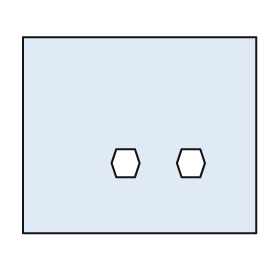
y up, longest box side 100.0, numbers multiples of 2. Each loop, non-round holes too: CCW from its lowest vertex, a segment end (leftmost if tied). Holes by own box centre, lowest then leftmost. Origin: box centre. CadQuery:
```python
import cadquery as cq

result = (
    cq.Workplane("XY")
    .moveTo(-50.0, -42.0)
    .lineTo(50.0, -42.0)
    .lineTo(50.0, 42.0)
    .lineTo(-50.0, 42.0)
    .close()
    .moveTo(-10.0, -18.0)
    .lineTo(-2.0, -18.0)
    .lineTo(0.0, -12.0)
    .lineTo(-2.0, -6.0)
    .lineTo(-10.0, -6.0)
    .lineTo(-12.0, -12.0)
    .close()
    .moveTo(18.0, -18.0)
    .lineTo(26.0, -18.0)
    .lineTo(28.0, -12.0)
    .lineTo(26.0, -6.0)
    .lineTo(18.0, -6.0)
    .lineTo(16.0, -12.0)
    .close()
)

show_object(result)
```